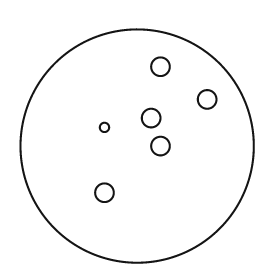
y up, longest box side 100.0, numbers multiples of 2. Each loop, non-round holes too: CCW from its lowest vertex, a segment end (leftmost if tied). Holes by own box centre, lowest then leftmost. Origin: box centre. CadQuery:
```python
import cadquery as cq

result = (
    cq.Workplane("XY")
    .moveTo(0.0, 0.0)
    .circle(50.0)
    .moveTo(-14.0, -20.0)
    .circle(4.0)
    .moveTo(10.0, 0.0)
    .circle(4.0)
    .moveTo(-14.0, 8.0)
    .circle(2.0)
    .moveTo(6.0, 12.0)
    .circle(4.0)
    .moveTo(30.0, 20.0)
    .circle(4.0)
    .moveTo(10.0, 34.0)
    .circle(4.0)
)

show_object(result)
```